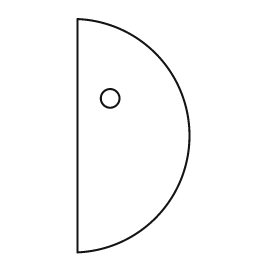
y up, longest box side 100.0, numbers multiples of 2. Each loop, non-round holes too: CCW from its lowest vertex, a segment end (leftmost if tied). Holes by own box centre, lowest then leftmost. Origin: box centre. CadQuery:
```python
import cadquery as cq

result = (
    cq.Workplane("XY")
    .moveTo(-24.0, -50.0)
    .threePointArc((24.0, 0.0), (-24.0, 50.0))
    .close()
    .moveTo(-10.0, 16.0)
    .circle(4.0)
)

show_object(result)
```